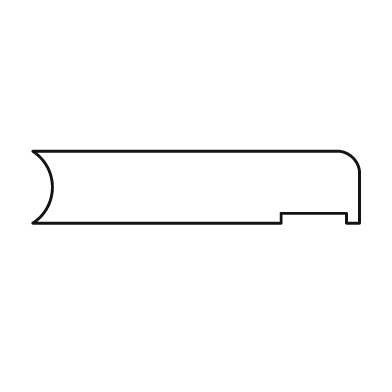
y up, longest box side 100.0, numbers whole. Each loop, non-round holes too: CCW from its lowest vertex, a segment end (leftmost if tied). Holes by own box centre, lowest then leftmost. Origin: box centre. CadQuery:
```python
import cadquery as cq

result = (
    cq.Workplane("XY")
    .moveTo(-50.0, -11.0)
    .lineTo(26.0, -11.0)
    .lineTo(26.0, -8.0)
    .lineTo(46.0, -8.0)
    .lineTo(46.0, -11.0)
    .lineTo(50.0, -11.0)
    .lineTo(50.0, 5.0)
    .threePointArc((48.0, 9.0), (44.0, 11.0))
    .lineTo(-50.0, 11.0)
    .threePointArc((-44.0, 0.0), (-50.0, -11.0))
    .close()
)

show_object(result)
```